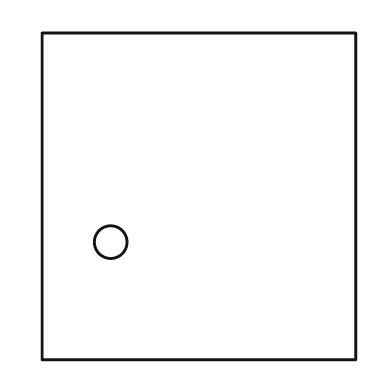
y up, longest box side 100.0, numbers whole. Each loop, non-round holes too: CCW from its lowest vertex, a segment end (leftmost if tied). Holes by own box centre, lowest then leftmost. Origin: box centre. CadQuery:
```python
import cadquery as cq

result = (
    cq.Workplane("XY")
    .moveTo(-48.0, -50.0)
    .lineTo(48.0, -50.0)
    .lineTo(48.0, 50.0)
    .lineTo(-48.0, 50.0)
    .close()
    .moveTo(-27.0, -14.0)
    .circle(5.0)
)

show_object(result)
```